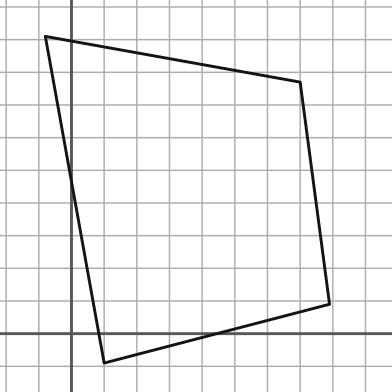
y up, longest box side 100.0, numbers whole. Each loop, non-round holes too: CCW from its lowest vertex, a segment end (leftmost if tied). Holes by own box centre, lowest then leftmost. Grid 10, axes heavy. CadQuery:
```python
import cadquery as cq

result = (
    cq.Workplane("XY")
    .moveTo(10.0, -9.0)
    .lineTo(79.0, 9.0)
    .lineTo(70.0, 77.0)
    .lineTo(-8.0, 91.0)
    .close()
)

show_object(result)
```